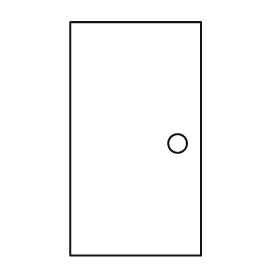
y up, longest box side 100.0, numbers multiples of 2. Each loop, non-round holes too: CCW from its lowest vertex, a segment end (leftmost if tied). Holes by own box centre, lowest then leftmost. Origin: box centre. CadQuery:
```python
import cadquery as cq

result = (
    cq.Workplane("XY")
    .moveTo(-28.0, -50.0)
    .lineTo(28.0, -50.0)
    .lineTo(28.0, 50.0)
    .lineTo(-28.0, 50.0)
    .close()
    .moveTo(18.0, -2.0)
    .circle(4.0)
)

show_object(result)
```